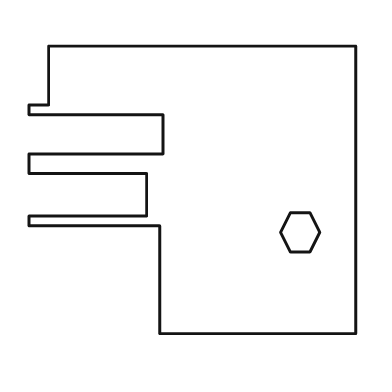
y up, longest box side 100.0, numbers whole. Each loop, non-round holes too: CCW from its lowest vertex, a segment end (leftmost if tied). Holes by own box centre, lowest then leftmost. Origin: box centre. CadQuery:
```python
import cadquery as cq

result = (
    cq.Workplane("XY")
    .moveTo(-10.0, -44.0)
    .lineTo(50.0, -44.0)
    .lineTo(50.0, 44.0)
    .lineTo(-44.0, 44.0)
    .lineTo(-44.0, 26.0)
    .lineTo(-50.0, 26.0)
    .lineTo(-50.0, 23.0)
    .lineTo(-9.0, 23.0)
    .lineTo(-9.0, 11.0)
    .lineTo(-50.0, 11.0)
    .lineTo(-50.0, 5.0)
    .lineTo(-14.0, 5.0)
    .lineTo(-14.0, -8.0)
    .lineTo(-50.0, -8.0)
    .lineTo(-50.0, -11.0)
    .lineTo(-10.0, -11.0)
    .close()
    .moveTo(30.0, -19.0)
    .lineTo(36.0, -19.0)
    .lineTo(39.0, -13.0)
    .lineTo(36.0, -7.0)
    .lineTo(30.0, -7.0)
    .lineTo(27.0, -13.0)
    .close()
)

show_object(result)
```